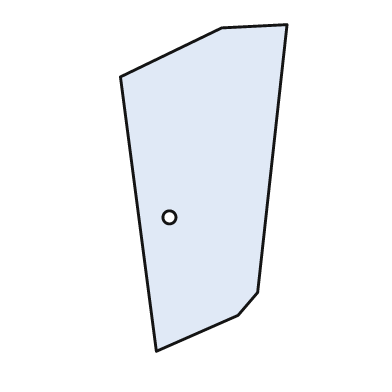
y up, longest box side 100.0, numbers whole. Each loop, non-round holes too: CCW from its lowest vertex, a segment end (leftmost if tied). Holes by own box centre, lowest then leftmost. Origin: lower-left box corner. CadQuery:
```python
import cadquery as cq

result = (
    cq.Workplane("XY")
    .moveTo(11.0, 0.0)
    .lineTo(36.0, 11.0)
    .lineTo(42.0, 18.0)
    .lineTo(51.0, 100.0)
    .lineTo(31.0, 99.0)
    .lineTo(0.0, 84.0)
    .close()
    .moveTo(15.0, 41.0)
    .circle(2.0)
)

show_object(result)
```